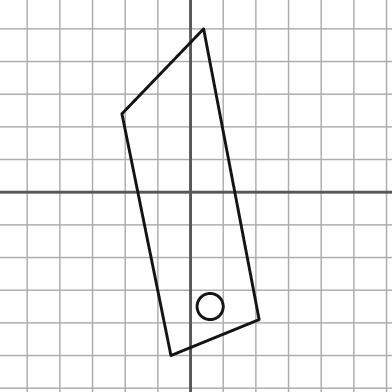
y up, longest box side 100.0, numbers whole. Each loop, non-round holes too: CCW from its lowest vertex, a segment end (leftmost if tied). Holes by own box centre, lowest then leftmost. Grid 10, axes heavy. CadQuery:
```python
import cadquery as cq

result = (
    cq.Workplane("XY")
    .moveTo(-6.0, -50.0)
    .lineTo(21.0, -39.0)
    .lineTo(4.0, 50.0)
    .lineTo(-21.0, 24.0)
    .close()
    .moveTo(6.0, -35.0)
    .circle(4.0)
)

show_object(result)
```